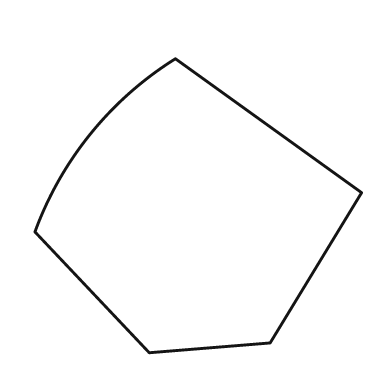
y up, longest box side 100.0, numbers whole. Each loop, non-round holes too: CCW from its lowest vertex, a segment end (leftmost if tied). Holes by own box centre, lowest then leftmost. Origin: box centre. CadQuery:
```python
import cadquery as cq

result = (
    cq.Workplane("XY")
    .moveTo(-15.0, -45.0)
    .lineTo(22.0, -42.0)
    .lineTo(50.0, 4.0)
    .lineTo(-7.0, 45.0)
    .threePointArc((-33.0, 22.0), (-50.0, -8.0))
    .close()
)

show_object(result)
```